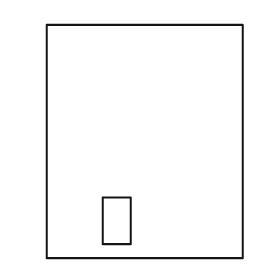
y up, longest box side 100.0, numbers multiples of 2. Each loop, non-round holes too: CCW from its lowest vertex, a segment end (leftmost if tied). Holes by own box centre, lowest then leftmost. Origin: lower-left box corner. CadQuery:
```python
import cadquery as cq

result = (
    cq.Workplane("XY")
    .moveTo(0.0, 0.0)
    .lineTo(84.0, 0.0)
    .lineTo(84.0, 100.0)
    .lineTo(0.0, 100.0)
    .close()
    .moveTo(24.0, 6.0)
    .lineTo(36.0, 6.0)
    .lineTo(36.0, 26.0)
    .lineTo(24.0, 26.0)
    .close()
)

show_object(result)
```